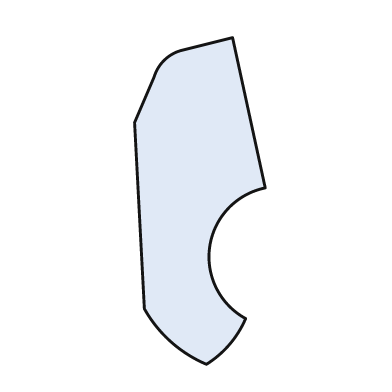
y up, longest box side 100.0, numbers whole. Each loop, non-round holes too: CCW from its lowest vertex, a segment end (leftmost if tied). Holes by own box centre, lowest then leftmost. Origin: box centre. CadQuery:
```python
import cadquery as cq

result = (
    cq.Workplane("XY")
    .moveTo(2.0, -50.0)
    .threePointArc((9.0, -44.0), (14.0, -36.0))
    .threePointArc((3.0, -14.0), (20.0, 4.0))
    .lineTo(10.0, 50.0)
    .lineTo(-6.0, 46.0)
    .threePointArc((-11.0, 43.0), (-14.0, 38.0))
    .lineTo(-20.0, 24.0)
    .lineTo(-17.0, -33.0)
    .threePointArc((-9.0, -43.0), (2.0, -50.0))
    .close()
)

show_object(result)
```